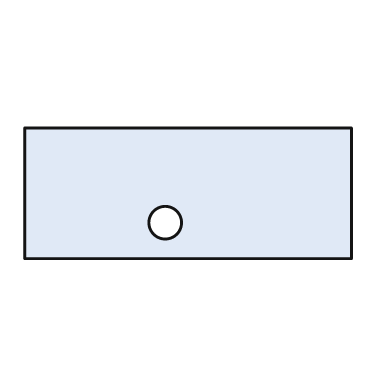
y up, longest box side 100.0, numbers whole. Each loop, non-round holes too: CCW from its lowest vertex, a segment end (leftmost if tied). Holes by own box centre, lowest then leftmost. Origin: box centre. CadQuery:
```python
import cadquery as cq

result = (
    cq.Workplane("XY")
    .moveTo(-50.0, -20.0)
    .lineTo(50.0, -20.0)
    .lineTo(50.0, 20.0)
    .lineTo(-50.0, 20.0)
    .close()
    .moveTo(-7.0, -9.0)
    .circle(5.0)
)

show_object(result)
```